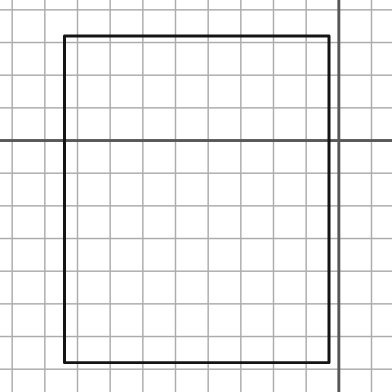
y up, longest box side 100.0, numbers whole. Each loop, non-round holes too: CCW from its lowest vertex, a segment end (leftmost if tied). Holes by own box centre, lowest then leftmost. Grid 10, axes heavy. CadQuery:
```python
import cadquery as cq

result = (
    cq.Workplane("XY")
    .moveTo(-84.0, -68.0)
    .lineTo(-3.0, -68.0)
    .lineTo(-3.0, 32.0)
    .lineTo(-84.0, 32.0)
    .close()
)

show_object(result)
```